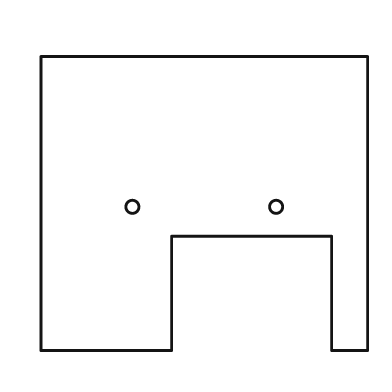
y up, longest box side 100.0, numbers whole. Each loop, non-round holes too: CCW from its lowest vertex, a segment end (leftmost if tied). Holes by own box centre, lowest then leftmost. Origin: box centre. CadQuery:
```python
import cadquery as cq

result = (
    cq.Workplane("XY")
    .moveTo(-50.0, -45.0)
    .lineTo(-10.0, -45.0)
    .lineTo(-10.0, -10.0)
    .lineTo(39.0, -10.0)
    .lineTo(39.0, -45.0)
    .lineTo(50.0, -45.0)
    .lineTo(50.0, 45.0)
    .lineTo(-50.0, 45.0)
    .close()
    .moveTo(-22.0, -1.0)
    .circle(2.0)
    .moveTo(22.0, -1.0)
    .circle(2.0)
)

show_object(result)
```